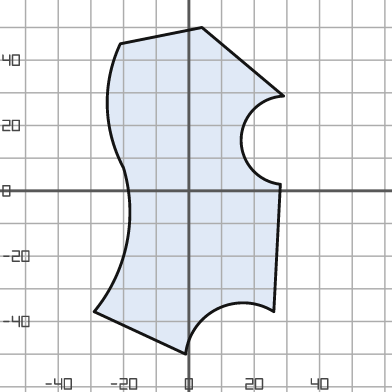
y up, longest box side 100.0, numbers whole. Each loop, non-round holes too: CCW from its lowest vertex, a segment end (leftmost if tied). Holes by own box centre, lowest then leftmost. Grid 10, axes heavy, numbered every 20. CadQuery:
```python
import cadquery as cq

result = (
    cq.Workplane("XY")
    .moveTo(-1.0, -50.0)
    .threePointArc((9.0, -36.0), (26.0, -37.0))
    .lineTo(28.0, 2.0)
    .threePointArc((16.0, 16.0), (29.0, 29.0))
    .lineTo(4.0, 50.0)
    .lineTo(-21.0, 45.0)
    .threePointArc((-25.0, 26.0), (-20.0, 7.0))
    .threePointArc((-19.0, -16.0), (-29.0, -37.0))
    .close()
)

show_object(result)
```